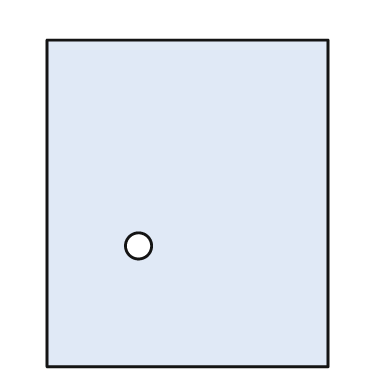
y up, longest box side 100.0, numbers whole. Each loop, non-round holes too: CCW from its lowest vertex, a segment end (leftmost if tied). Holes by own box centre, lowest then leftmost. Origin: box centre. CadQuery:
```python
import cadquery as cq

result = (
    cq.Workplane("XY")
    .moveTo(-43.0, -50.0)
    .lineTo(43.0, -50.0)
    .lineTo(43.0, 50.0)
    .lineTo(-43.0, 50.0)
    .close()
    .moveTo(-15.0, -13.0)
    .circle(4.0)
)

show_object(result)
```